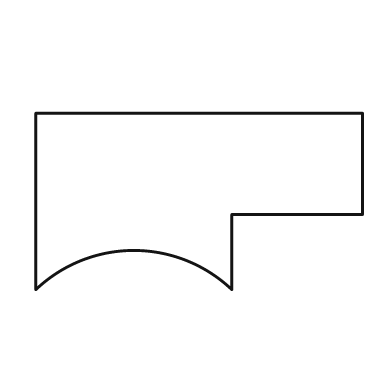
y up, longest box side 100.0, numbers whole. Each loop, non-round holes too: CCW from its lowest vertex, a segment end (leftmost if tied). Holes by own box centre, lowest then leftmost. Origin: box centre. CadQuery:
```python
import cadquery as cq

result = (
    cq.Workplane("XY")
    .moveTo(-50.0, -27.0)
    .threePointArc((-20.0, -15.0), (10.0, -27.0))
    .lineTo(10.0, -4.0)
    .lineTo(50.0, -4.0)
    .lineTo(50.0, 27.0)
    .lineTo(-50.0, 27.0)
    .close()
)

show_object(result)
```